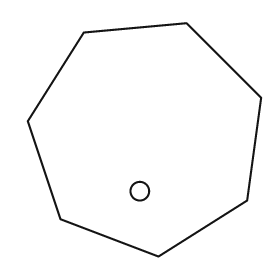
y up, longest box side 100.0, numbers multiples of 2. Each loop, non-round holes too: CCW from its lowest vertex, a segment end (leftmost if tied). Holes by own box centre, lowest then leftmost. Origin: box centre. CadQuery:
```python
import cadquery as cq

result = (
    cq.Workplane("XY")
    .moveTo(6.0, -50.0)
    .lineTo(44.0, -26.0)
    .lineTo(50.0, 18.0)
    .lineTo(18.0, 50.0)
    .lineTo(-26.0, 46.0)
    .lineTo(-50.0, 8.0)
    .lineTo(-36.0, -34.0)
    .close()
    .moveTo(-2.0, -22.0)
    .circle(4.0)
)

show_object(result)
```